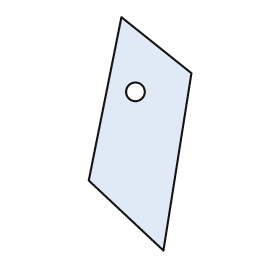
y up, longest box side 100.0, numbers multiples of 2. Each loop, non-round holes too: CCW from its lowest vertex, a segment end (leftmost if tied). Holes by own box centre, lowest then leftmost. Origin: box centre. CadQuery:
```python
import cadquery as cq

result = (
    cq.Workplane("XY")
    .moveTo(10.0, -50.0)
    .lineTo(22.0, 26.0)
    .lineTo(-8.0, 50.0)
    .lineTo(-22.0, -20.0)
    .close()
    .moveTo(-2.0, 18.0)
    .circle(4.0)
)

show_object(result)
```